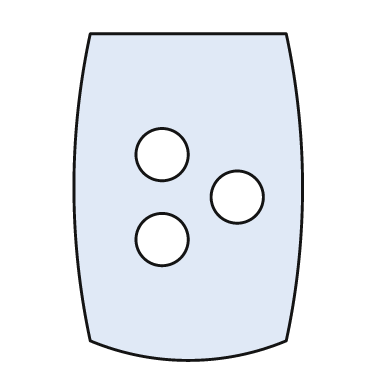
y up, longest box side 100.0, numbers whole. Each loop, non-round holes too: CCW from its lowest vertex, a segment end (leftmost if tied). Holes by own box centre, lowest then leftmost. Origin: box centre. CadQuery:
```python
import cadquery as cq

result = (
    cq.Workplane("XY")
    .moveTo(-30.0, -44.0)
    .threePointArc((0.0, -50.0), (30.0, -44.0))
    .threePointArc((35.0, 3.0), (30.0, 50.0))
    .lineTo(-30.0, 50.0)
    .threePointArc((-35.0, 3.0), (-30.0, -44.0))
    .close()
    .moveTo(-8.0, -13.0)
    .circle(8.0)
    .moveTo(15.0, 0.0)
    .circle(8.0)
    .moveTo(-8.0, 13.0)
    .circle(8.0)
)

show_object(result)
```